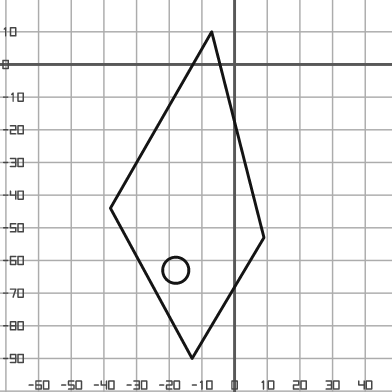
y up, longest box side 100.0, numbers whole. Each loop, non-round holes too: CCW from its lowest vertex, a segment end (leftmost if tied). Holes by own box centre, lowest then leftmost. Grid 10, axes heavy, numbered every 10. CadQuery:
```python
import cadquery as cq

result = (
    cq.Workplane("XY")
    .moveTo(-13.0, -90.0)
    .lineTo(9.0, -53.0)
    .lineTo(-7.0, 10.0)
    .lineTo(-38.0, -44.0)
    .close()
    .moveTo(-18.0, -63.0)
    .circle(4.0)
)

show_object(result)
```